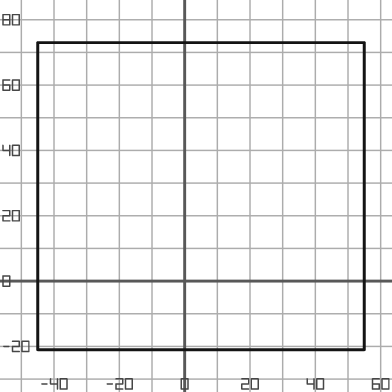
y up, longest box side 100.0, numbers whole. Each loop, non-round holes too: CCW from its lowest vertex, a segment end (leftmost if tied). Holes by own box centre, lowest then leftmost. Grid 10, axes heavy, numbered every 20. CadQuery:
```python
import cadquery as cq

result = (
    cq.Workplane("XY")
    .moveTo(-45.0, -21.0)
    .lineTo(55.0, -21.0)
    .lineTo(55.0, 73.0)
    .lineTo(-45.0, 73.0)
    .close()
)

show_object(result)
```